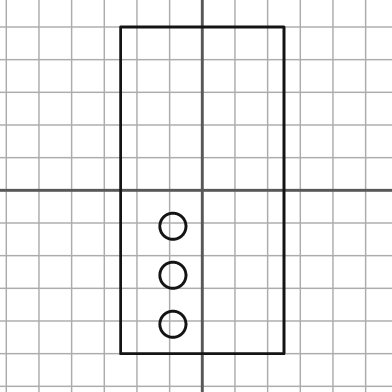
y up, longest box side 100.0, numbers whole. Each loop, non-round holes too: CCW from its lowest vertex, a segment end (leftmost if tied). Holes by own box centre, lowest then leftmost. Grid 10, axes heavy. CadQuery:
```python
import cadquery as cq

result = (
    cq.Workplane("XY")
    .moveTo(-25.0, -50.0)
    .lineTo(25.0, -50.0)
    .lineTo(25.0, 50.0)
    .lineTo(-25.0, 50.0)
    .close()
    .moveTo(-9.0, -41.0)
    .circle(4.0)
    .moveTo(-9.0, -26.0)
    .circle(4.0)
    .moveTo(-9.0, -11.0)
    .circle(4.0)
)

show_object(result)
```